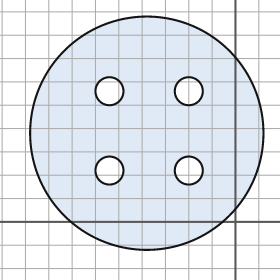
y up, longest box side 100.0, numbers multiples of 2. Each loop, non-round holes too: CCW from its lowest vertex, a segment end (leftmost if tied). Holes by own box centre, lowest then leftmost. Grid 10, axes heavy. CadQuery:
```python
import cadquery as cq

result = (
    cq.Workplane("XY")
    .moveTo(-38.0, 38.0)
    .circle(50.0)
    .moveTo(-54.0, 22.0)
    .circle(6.0)
    .moveTo(-20.0, 22.0)
    .circle(6.0)
    .moveTo(-54.0, 56.0)
    .circle(6.0)
    .moveTo(-20.0, 56.0)
    .circle(6.0)
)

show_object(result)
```